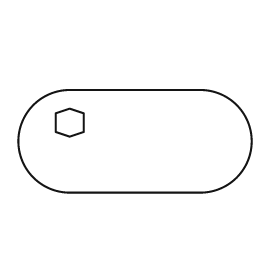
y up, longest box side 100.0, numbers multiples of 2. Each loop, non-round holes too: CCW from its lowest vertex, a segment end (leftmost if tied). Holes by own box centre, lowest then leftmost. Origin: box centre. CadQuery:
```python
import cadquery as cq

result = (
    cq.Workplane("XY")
    .moveTo(-28.0, -22.0)
    .lineTo(28.0, -22.0)
    .threePointArc((50.0, 0.0), (28.0, 22.0))
    .lineTo(-28.0, 22.0)
    .threePointArc((-50.0, 0.0), (-28.0, -22.0))
    .close()
    .moveTo(-28.0, 2.0)
    .lineTo(-22.0, 4.0)
    .lineTo(-22.0, 12.0)
    .lineTo(-28.0, 14.0)
    .lineTo(-34.0, 12.0)
    .lineTo(-34.0, 4.0)
    .close()
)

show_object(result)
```